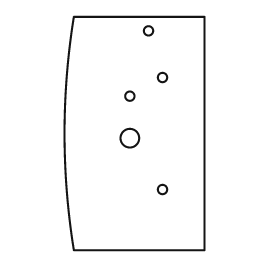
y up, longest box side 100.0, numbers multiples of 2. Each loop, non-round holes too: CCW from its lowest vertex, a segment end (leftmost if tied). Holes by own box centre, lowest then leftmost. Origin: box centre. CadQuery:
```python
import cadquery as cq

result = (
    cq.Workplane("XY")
    .moveTo(-26.0, -50.0)
    .lineTo(30.0, -50.0)
    .lineTo(30.0, 50.0)
    .lineTo(-26.0, 50.0)
    .threePointArc((-30.0, 0.0), (-26.0, -50.0))
    .close()
    .moveTo(12.0, -24.0)
    .circle(2.0)
    .moveTo(-2.0, -2.0)
    .circle(4.0)
    .moveTo(-2.0, 16.0)
    .circle(2.0)
    .moveTo(12.0, 24.0)
    .circle(2.0)
    .moveTo(6.0, 44.0)
    .circle(2.0)
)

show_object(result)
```